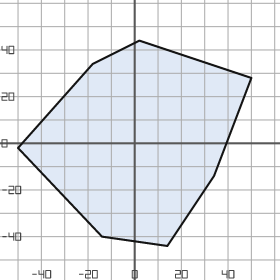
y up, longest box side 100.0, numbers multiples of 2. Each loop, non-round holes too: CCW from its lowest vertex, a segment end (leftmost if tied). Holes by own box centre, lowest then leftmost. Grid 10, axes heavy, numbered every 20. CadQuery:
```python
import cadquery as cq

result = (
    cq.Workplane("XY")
    .moveTo(14.0, -44.0)
    .lineTo(34.0, -14.0)
    .lineTo(50.0, 28.0)
    .lineTo(2.0, 44.0)
    .lineTo(-18.0, 34.0)
    .lineTo(-50.0, -2.0)
    .lineTo(-14.0, -40.0)
    .close()
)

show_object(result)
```